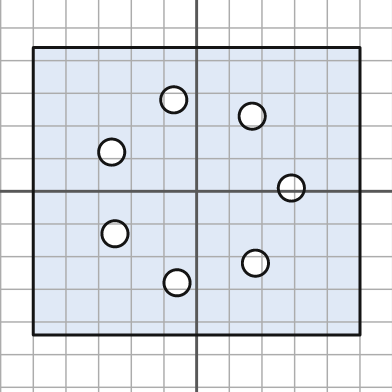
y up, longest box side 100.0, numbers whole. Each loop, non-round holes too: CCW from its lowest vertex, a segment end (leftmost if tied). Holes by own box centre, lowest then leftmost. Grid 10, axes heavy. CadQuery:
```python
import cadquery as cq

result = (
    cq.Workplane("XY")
    .moveTo(-50.0, -44.0)
    .lineTo(50.0, -44.0)
    .lineTo(50.0, 44.0)
    .lineTo(-50.0, 44.0)
    .close()
    .moveTo(-6.0, -28.0)
    .circle(4.0)
    .moveTo(18.0, -22.0)
    .circle(4.0)
    .moveTo(-25.0, -13.0)
    .circle(4.0)
    .moveTo(29.0, 1.0)
    .circle(4.0)
    .moveTo(-26.0, 12.0)
    .circle(4.0)
    .moveTo(17.0, 23.0)
    .circle(4.0)
    .moveTo(-7.0, 28.0)
    .circle(4.0)
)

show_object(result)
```